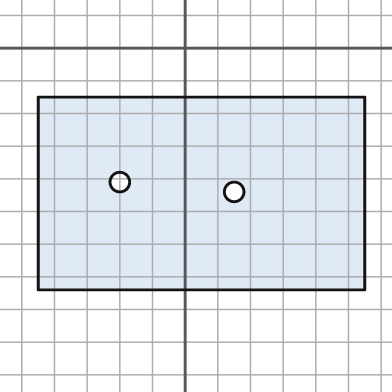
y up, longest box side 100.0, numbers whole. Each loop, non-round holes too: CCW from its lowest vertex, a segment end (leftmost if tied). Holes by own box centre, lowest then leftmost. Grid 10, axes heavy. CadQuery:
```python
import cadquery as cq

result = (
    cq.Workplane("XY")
    .moveTo(-45.0, -74.0)
    .lineTo(55.0, -74.0)
    .lineTo(55.0, -15.0)
    .lineTo(-45.0, -15.0)
    .close()
    .moveTo(15.0, -44.0)
    .circle(3.0)
    .moveTo(-20.0, -41.0)
    .circle(3.0)
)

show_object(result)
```